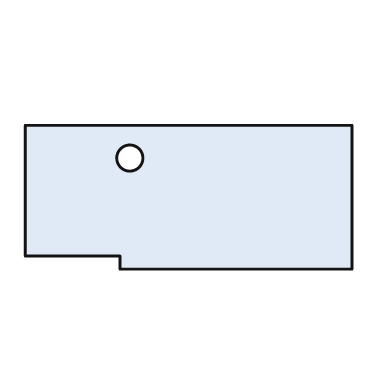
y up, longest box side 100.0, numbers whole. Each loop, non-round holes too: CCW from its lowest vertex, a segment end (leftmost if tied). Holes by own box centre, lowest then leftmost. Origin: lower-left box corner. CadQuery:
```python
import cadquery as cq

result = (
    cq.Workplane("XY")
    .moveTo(29.0, 0.0)
    .lineTo(100.0, 0.0)
    .lineTo(100.0, 44.0)
    .lineTo(0.0, 44.0)
    .lineTo(0.0, 4.0)
    .lineTo(29.0, 4.0)
    .close()
    .moveTo(32.0, 34.0)
    .circle(4.0)
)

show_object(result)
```